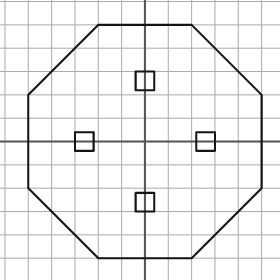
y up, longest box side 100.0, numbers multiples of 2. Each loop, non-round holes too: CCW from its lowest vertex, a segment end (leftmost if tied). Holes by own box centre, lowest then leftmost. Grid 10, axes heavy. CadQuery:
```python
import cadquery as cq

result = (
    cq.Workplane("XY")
    .moveTo(-20.0, -50.0)
    .lineTo(20.0, -50.0)
    .lineTo(50.0, -20.0)
    .lineTo(50.0, 20.0)
    .lineTo(20.0, 50.0)
    .lineTo(-20.0, 50.0)
    .lineTo(-50.0, 20.0)
    .lineTo(-50.0, -20.0)
    .close()
    .moveTo(-4.0, -30.0)
    .lineTo(4.0, -30.0)
    .lineTo(4.0, -22.0)
    .lineTo(-4.0, -22.0)
    .close()
    .moveTo(-30.0, -4.0)
    .lineTo(-22.0, -4.0)
    .lineTo(-22.0, 4.0)
    .lineTo(-30.0, 4.0)
    .close()
    .moveTo(22.0, -4.0)
    .lineTo(30.0, -4.0)
    .lineTo(30.0, 4.0)
    .lineTo(22.0, 4.0)
    .close()
    .moveTo(-4.0, 22.0)
    .lineTo(4.0, 22.0)
    .lineTo(4.0, 30.0)
    .lineTo(-4.0, 30.0)
    .close()
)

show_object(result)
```